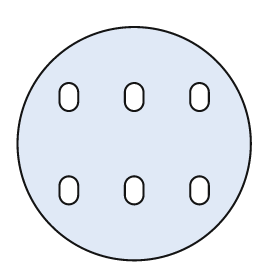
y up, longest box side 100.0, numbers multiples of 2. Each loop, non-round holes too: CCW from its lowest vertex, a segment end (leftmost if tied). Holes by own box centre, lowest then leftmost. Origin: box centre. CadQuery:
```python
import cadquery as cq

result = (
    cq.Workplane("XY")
    .moveTo(0.0, 0.0)
    .circle(50.0)
    .moveTo(-32.0, -22.0)
    .threePointArc((-28.0, -26.0), (-24.0, -22.0))
    .lineTo(-24.0, -18.0)
    .threePointArc((-28.0, -14.0), (-32.0, -18.0))
    .close()
    .moveTo(-4.0, -22.0)
    .threePointArc((0.0, -26.0), (4.0, -22.0))
    .lineTo(4.0, -18.0)
    .threePointArc((0.0, -14.0), (-4.0, -18.0))
    .close()
    .moveTo(24.0, -22.0)
    .threePointArc((28.0, -26.0), (32.0, -22.0))
    .lineTo(32.0, -18.0)
    .threePointArc((28.0, -14.0), (24.0, -18.0))
    .close()
    .moveTo(-32.0, 18.0)
    .threePointArc((-28.0, 14.0), (-24.0, 18.0))
    .lineTo(-24.0, 22.0)
    .threePointArc((-28.0, 26.0), (-32.0, 22.0))
    .close()
    .moveTo(-4.0, 18.0)
    .threePointArc((0.0, 14.0), (4.0, 18.0))
    .lineTo(4.0, 22.0)
    .threePointArc((0.0, 26.0), (-4.0, 22.0))
    .close()
    .moveTo(24.0, 18.0)
    .threePointArc((28.0, 14.0), (32.0, 18.0))
    .lineTo(32.0, 22.0)
    .threePointArc((28.0, 26.0), (24.0, 22.0))
    .close()
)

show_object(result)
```